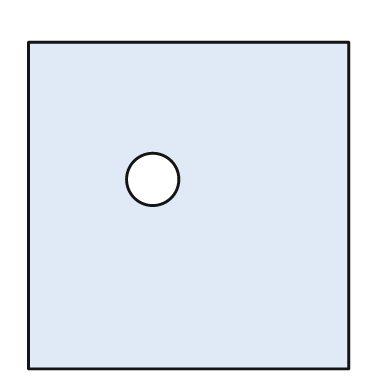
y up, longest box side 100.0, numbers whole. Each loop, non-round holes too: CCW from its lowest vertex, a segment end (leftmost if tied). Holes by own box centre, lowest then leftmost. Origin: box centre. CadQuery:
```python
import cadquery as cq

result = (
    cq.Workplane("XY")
    .moveTo(-49.0, -50.0)
    .lineTo(49.0, -50.0)
    .lineTo(49.0, 50.0)
    .lineTo(-49.0, 50.0)
    .close()
    .moveTo(-11.0, 8.0)
    .circle(8.0)
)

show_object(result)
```